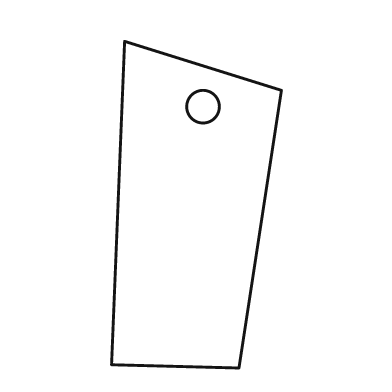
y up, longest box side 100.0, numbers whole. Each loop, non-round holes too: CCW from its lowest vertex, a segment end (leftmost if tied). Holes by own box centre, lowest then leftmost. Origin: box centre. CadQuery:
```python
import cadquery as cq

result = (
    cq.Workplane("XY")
    .moveTo(13.0, -50.0)
    .lineTo(26.0, 35.0)
    .lineTo(-22.0, 50.0)
    .lineTo(-26.0, -49.0)
    .close()
    .moveTo(2.0, 30.0)
    .circle(5.0)
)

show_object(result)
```